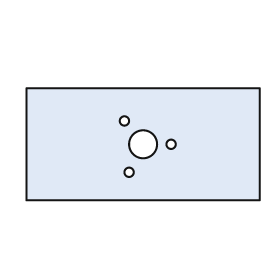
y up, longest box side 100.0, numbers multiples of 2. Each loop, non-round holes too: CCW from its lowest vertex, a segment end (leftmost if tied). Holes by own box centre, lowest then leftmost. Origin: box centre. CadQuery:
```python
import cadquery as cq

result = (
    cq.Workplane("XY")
    .moveTo(-50.0, -24.0)
    .lineTo(50.0, -24.0)
    .lineTo(50.0, 24.0)
    .lineTo(-50.0, 24.0)
    .close()
    .moveTo(-6.0, -12.0)
    .circle(2.0)
    .moveTo(0.0, 0.0)
    .circle(6.0)
    .moveTo(12.0, 0.0)
    .circle(2.0)
    .moveTo(-8.0, 10.0)
    .circle(2.0)
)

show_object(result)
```